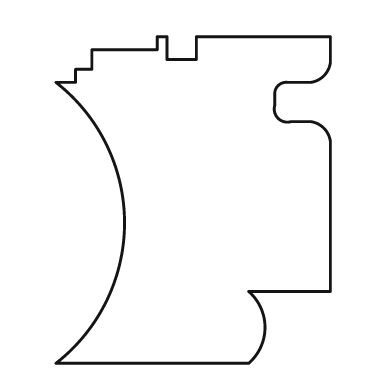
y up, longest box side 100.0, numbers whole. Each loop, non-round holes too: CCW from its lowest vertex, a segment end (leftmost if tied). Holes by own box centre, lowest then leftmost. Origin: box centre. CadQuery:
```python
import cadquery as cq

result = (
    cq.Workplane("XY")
    .moveTo(-42.0, -50.0)
    .lineTo(17.0, -50.0)
    .threePointArc((22.0, -39.0), (17.0, -28.0))
    .lineTo(42.0, -28.0)
    .lineTo(42.0, 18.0)
    .threePointArc((40.0, 22.0), (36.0, 24.0))
    .lineTo(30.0, 24.0)
    .threePointArc((26.0, 25.0), (25.0, 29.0))
    .lineTo(25.0, 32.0)
    .threePointArc((26.0, 35.0), (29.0, 36.0))
    .lineTo(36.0, 36.0)
    .threePointArc((40.0, 38.0), (42.0, 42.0))
    .lineTo(42.0, 50.0)
    .lineTo(1.0, 50.0)
    .lineTo(1.0, 43.0)
    .lineTo(-8.0, 43.0)
    .lineTo(-8.0, 50.0)
    .lineTo(-11.0, 50.0)
    .lineTo(-11.0, 46.0)
    .lineTo(-31.0, 46.0)
    .lineTo(-31.0, 40.0)
    .lineTo(-36.0, 40.0)
    .lineTo(-36.0, 36.0)
    .lineTo(-42.0, 36.0)
    .threePointArc((-21.0, -7.0), (-42.0, -50.0))
    .close()
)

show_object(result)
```